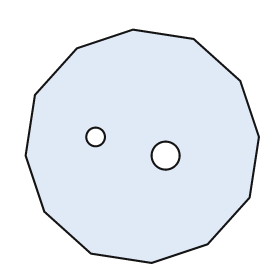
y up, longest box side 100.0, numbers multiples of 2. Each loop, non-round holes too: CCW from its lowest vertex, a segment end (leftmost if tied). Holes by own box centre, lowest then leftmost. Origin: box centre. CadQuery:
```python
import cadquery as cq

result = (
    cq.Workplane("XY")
    .moveTo(4.0, -50.0)
    .lineTo(28.0, -42.0)
    .lineTo(46.0, -22.0)
    .lineTo(50.0, 4.0)
    .lineTo(42.0, 28.0)
    .lineTo(22.0, 46.0)
    .lineTo(-4.0, 50.0)
    .lineTo(-28.0, 42.0)
    .lineTo(-46.0, 22.0)
    .lineTo(-50.0, -4.0)
    .lineTo(-42.0, -28.0)
    .lineTo(-22.0, -46.0)
    .close()
    .moveTo(10.0, -4.0)
    .circle(6.0)
    .moveTo(-20.0, 4.0)
    .circle(4.0)
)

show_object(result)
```